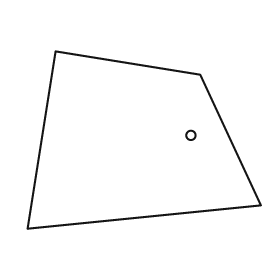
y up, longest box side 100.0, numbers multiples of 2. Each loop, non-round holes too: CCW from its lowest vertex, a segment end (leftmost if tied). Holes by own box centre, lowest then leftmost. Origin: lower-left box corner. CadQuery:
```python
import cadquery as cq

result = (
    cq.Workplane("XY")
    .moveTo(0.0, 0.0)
    .lineTo(100.0, 10.0)
    .lineTo(74.0, 66.0)
    .lineTo(12.0, 76.0)
    .close()
    .moveTo(70.0, 40.0)
    .circle(2.0)
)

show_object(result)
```